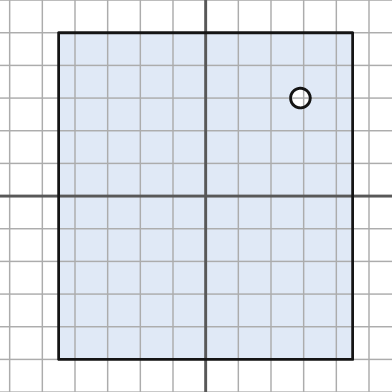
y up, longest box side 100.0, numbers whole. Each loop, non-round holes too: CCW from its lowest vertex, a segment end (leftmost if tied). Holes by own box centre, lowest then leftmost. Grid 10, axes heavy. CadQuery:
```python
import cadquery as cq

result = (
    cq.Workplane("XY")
    .moveTo(-45.0, -50.0)
    .lineTo(45.0, -50.0)
    .lineTo(45.0, 50.0)
    .lineTo(-45.0, 50.0)
    .close()
    .moveTo(29.0, 30.0)
    .circle(3.0)
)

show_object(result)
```